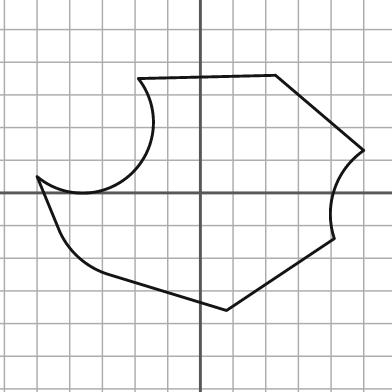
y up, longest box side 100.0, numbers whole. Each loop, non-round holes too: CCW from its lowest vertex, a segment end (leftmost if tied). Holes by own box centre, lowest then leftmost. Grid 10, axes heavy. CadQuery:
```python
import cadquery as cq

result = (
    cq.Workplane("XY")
    .moveTo(8.0, -36.0)
    .lineTo(41.0, -14.0)
    .threePointArc((41.0, 1.0), (50.0, 13.0))
    .lineTo(23.0, 36.0)
    .lineTo(-19.0, 35.0)
    .threePointArc((-21.0, 6.0), (-50.0, 5.0))
    .lineTo(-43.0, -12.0)
    .threePointArc((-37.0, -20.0), (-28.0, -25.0))
    .close()
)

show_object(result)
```